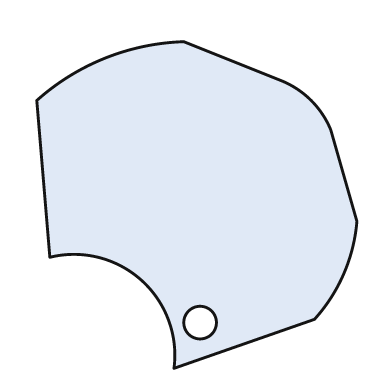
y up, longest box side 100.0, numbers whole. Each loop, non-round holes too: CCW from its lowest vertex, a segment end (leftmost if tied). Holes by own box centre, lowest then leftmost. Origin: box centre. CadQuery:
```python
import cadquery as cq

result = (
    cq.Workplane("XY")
    .moveTo(-7.0, -50.0)
    .lineTo(36.0, -35.0)
    .threePointArc((45.0, -21.0), (49.0, -5.0))
    .lineTo(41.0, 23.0)
    .threePointArc((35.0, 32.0), (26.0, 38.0))
    .lineTo(-4.0, 50.0)
    .threePointArc((-28.0, 45.0), (-49.0, 32.0))
    .lineTo(-45.0, -16.0)
    .threePointArc((-17.0, -23.0), (-7.0, -50.0))
    .close()
    .moveTo(1.0, -36.0)
    .circle(5.0)
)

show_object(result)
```